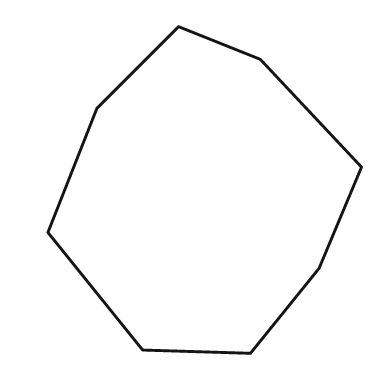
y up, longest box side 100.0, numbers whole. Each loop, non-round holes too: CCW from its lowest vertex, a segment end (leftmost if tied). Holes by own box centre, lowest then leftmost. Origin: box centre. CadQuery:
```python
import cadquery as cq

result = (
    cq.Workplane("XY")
    .moveTo(14.0, -50.0)
    .lineTo(35.0, -24.0)
    .lineTo(48.0, 7.0)
    .lineTo(17.0, 40.0)
    .lineTo(-8.0, 50.0)
    .lineTo(-33.0, 25.0)
    .lineTo(-48.0, -13.0)
    .lineTo(-19.0, -49.0)
    .close()
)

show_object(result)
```